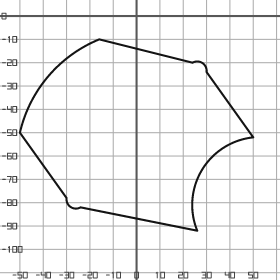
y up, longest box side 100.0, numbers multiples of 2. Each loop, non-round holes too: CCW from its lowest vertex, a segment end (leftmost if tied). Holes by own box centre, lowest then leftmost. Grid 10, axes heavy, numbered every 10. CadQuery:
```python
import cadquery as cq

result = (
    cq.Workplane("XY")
    .moveTo(26.0, -92.0)
    .threePointArc((28.0, -66.0), (50.0, -52.0))
    .lineTo(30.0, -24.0)
    .threePointArc((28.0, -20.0), (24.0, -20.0))
    .lineTo(-16.0, -10.0)
    .threePointArc((-38.0, -26.0), (-50.0, -50.0))
    .lineTo(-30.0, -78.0)
    .threePointArc((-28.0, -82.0), (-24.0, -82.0))
    .close()
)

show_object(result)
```